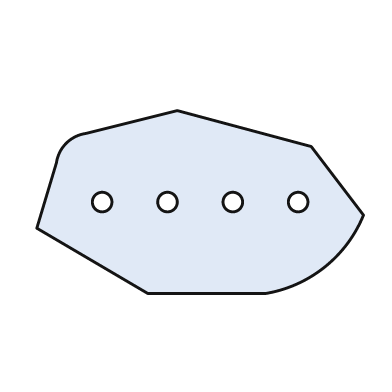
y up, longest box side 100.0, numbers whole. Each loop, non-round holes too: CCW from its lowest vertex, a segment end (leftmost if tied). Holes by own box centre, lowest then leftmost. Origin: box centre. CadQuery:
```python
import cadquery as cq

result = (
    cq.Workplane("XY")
    .moveTo(-16.0, -28.0)
    .lineTo(20.0, -28.0)
    .threePointArc((38.0, -20.0), (50.0, -4.0))
    .lineTo(34.0, 17.0)
    .lineTo(-7.0, 28.0)
    .lineTo(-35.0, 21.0)
    .threePointArc((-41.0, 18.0), (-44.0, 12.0))
    .lineTo(-50.0, -8.0)
    .close()
    .moveTo(-30.0, 0.0)
    .circle(3.0)
    .moveTo(-10.0, 0.0)
    .circle(3.0)
    .moveTo(10.0, 0.0)
    .circle(3.0)
    .moveTo(30.0, 0.0)
    .circle(3.0)
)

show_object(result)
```